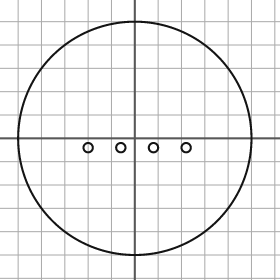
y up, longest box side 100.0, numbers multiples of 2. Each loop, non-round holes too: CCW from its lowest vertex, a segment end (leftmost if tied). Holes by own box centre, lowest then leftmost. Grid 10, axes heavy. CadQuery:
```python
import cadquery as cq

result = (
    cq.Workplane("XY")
    .moveTo(0.0, 0.0)
    .circle(50.0)
    .moveTo(-20.0, -4.0)
    .circle(2.0)
    .moveTo(-6.0, -4.0)
    .circle(2.0)
    .moveTo(8.0, -4.0)
    .circle(2.0)
    .moveTo(22.0, -4.0)
    .circle(2.0)
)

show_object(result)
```